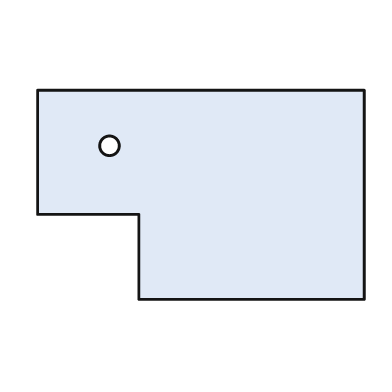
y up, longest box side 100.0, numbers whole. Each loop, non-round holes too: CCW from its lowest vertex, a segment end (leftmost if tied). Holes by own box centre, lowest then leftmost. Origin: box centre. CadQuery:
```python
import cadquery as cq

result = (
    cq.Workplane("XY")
    .moveTo(-19.0, -32.0)
    .lineTo(50.0, -32.0)
    .lineTo(50.0, 32.0)
    .lineTo(-50.0, 32.0)
    .lineTo(-50.0, -6.0)
    .lineTo(-19.0, -6.0)
    .close()
    .moveTo(-28.0, 15.0)
    .circle(3.0)
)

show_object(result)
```